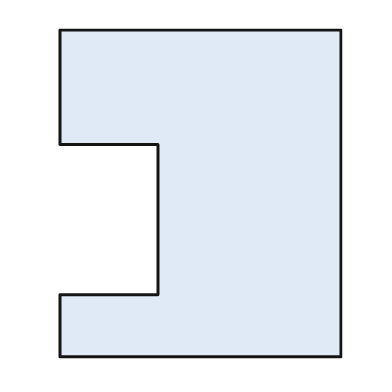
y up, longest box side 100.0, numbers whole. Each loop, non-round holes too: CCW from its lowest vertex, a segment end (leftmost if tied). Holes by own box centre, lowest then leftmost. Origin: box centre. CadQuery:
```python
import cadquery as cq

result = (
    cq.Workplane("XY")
    .moveTo(-43.0, -50.0)
    .lineTo(43.0, -50.0)
    .lineTo(43.0, 50.0)
    .lineTo(-43.0, 50.0)
    .lineTo(-43.0, 15.0)
    .lineTo(-13.0, 15.0)
    .lineTo(-13.0, -31.0)
    .lineTo(-43.0, -31.0)
    .close()
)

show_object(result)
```